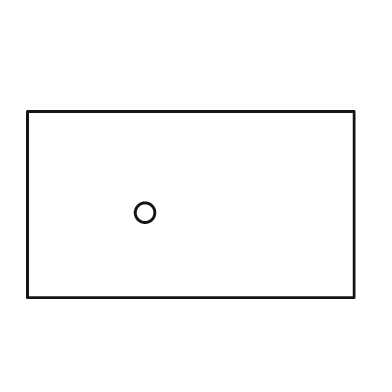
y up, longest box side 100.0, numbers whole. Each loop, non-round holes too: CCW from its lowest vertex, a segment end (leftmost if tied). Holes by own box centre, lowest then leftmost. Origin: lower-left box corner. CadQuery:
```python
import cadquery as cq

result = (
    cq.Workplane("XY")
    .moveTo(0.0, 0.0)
    .lineTo(100.0, 0.0)
    .lineTo(100.0, 57.0)
    .lineTo(0.0, 57.0)
    .close()
    .moveTo(36.0, 26.0)
    .circle(3.0)
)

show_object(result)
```